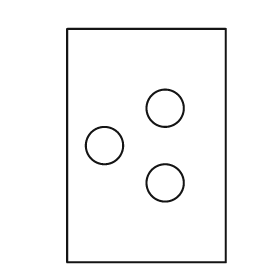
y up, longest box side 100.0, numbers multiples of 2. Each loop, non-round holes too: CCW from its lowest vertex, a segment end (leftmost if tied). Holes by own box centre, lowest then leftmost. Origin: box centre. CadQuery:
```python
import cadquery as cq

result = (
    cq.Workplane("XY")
    .moveTo(-34.0, -50.0)
    .lineTo(34.0, -50.0)
    .lineTo(34.0, 50.0)
    .lineTo(-34.0, 50.0)
    .close()
    .moveTo(8.0, -16.0)
    .circle(8.0)
    .moveTo(-18.0, 0.0)
    .circle(8.0)
    .moveTo(8.0, 16.0)
    .circle(8.0)
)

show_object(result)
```